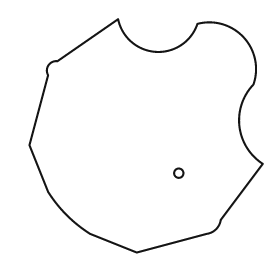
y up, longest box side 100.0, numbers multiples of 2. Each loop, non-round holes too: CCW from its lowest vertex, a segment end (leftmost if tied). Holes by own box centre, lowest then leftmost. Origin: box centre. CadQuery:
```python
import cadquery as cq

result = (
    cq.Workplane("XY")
    .moveTo(-4.0, -50.0)
    .lineTo(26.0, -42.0)
    .threePointArc((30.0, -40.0), (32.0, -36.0))
    .lineTo(50.0, -12.0)
    .threePointArc((40.0, 4.0), (46.0, 22.0))
    .threePointArc((42.0, 42.0), (22.0, 48.0))
    .threePointArc((4.0, 36.0), (-12.0, 50.0))
    .lineTo(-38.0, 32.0)
    .threePointArc((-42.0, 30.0), (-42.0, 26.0))
    .lineTo(-50.0, -4.0)
    .lineTo(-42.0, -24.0)
    .threePointArc((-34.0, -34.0), (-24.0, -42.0))
    .close()
    .moveTo(14.0, -16.0)
    .circle(2.0)
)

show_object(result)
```